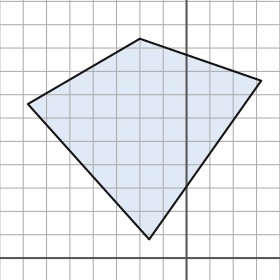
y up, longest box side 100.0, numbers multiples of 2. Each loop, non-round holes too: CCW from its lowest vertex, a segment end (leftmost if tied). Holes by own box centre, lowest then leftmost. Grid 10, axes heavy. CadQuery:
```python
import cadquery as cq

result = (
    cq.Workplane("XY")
    .moveTo(-16.0, 8.0)
    .lineTo(32.0, 76.0)
    .lineTo(-20.0, 94.0)
    .lineTo(-68.0, 66.0)
    .close()
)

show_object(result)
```